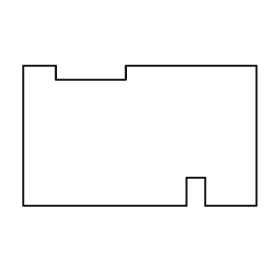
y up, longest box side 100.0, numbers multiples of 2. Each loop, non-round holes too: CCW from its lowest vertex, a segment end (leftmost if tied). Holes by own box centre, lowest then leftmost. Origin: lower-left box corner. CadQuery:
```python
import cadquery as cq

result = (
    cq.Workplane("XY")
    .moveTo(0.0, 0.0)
    .lineTo(70.0, 0.0)
    .lineTo(70.0, 12.0)
    .lineTo(78.0, 12.0)
    .lineTo(78.0, 0.0)
    .lineTo(100.0, 0.0)
    .lineTo(100.0, 60.0)
    .lineTo(44.0, 60.0)
    .lineTo(44.0, 54.0)
    .lineTo(14.0, 54.0)
    .lineTo(14.0, 60.0)
    .lineTo(0.0, 60.0)
    .close()
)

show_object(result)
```